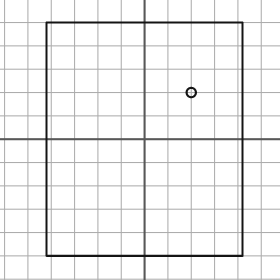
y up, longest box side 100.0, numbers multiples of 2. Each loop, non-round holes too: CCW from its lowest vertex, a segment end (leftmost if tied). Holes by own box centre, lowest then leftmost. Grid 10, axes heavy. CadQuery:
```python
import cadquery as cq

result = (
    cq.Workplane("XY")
    .moveTo(-42.0, -50.0)
    .lineTo(42.0, -50.0)
    .lineTo(42.0, 50.0)
    .lineTo(-42.0, 50.0)
    .close()
    .moveTo(20.0, 20.0)
    .circle(2.0)
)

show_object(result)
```